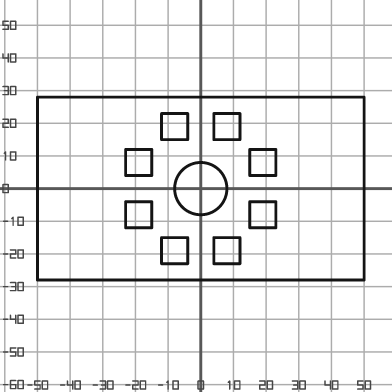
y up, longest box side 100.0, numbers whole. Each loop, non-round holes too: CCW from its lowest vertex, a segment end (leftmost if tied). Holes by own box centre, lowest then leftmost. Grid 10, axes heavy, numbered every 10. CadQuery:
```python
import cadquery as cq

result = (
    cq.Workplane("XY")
    .moveTo(-50.0, -28.0)
    .lineTo(50.0, -28.0)
    .lineTo(50.0, 28.0)
    .lineTo(-50.0, 28.0)
    .close()
    .moveTo(-12.0, -23.0)
    .lineTo(-4.0, -23.0)
    .lineTo(-4.0, -15.0)
    .lineTo(-12.0, -15.0)
    .close()
    .moveTo(4.0, -23.0)
    .lineTo(12.0, -23.0)
    .lineTo(12.0, -15.0)
    .lineTo(4.0, -15.0)
    .close()
    .moveTo(-23.0, -12.0)
    .lineTo(-15.0, -12.0)
    .lineTo(-15.0, -4.0)
    .lineTo(-23.0, -4.0)
    .close()
    .moveTo(15.0, -12.0)
    .lineTo(23.0, -12.0)
    .lineTo(23.0, -4.0)
    .lineTo(15.0, -4.0)
    .close()
    .moveTo(0.0, 0.0)
    .circle(8.0)
    .moveTo(-23.0, 4.0)
    .lineTo(-15.0, 4.0)
    .lineTo(-15.0, 12.0)
    .lineTo(-23.0, 12.0)
    .close()
    .moveTo(15.0, 4.0)
    .lineTo(23.0, 4.0)
    .lineTo(23.0, 12.0)
    .lineTo(15.0, 12.0)
    .close()
    .moveTo(-12.0, 15.0)
    .lineTo(-4.0, 15.0)
    .lineTo(-4.0, 23.0)
    .lineTo(-12.0, 23.0)
    .close()
    .moveTo(4.0, 15.0)
    .lineTo(12.0, 15.0)
    .lineTo(12.0, 23.0)
    .lineTo(4.0, 23.0)
    .close()
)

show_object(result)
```